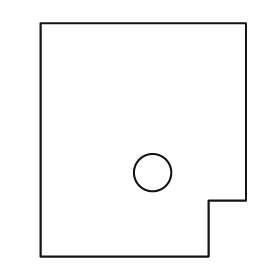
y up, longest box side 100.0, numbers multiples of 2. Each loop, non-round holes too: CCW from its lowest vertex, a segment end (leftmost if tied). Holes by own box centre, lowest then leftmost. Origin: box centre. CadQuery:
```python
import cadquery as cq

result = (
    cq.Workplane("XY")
    .moveTo(-44.0, -50.0)
    .lineTo(28.0, -50.0)
    .lineTo(28.0, -26.0)
    .lineTo(44.0, -26.0)
    .lineTo(44.0, 50.0)
    .lineTo(-44.0, 50.0)
    .close()
    .moveTo(4.0, -14.0)
    .circle(8.0)
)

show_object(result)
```